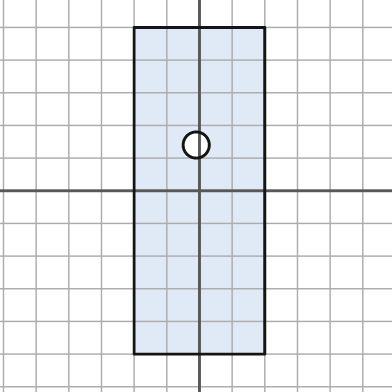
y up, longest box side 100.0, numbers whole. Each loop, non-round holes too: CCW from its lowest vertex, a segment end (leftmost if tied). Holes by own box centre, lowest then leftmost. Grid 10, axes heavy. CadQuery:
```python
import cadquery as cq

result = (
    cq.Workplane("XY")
    .moveTo(-20.0, -50.0)
    .lineTo(20.0, -50.0)
    .lineTo(20.0, 50.0)
    .lineTo(-20.0, 50.0)
    .close()
    .moveTo(-1.0, 14.0)
    .circle(4.0)
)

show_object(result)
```